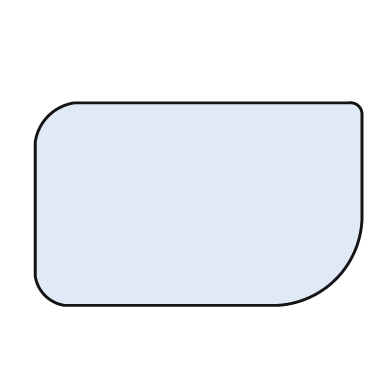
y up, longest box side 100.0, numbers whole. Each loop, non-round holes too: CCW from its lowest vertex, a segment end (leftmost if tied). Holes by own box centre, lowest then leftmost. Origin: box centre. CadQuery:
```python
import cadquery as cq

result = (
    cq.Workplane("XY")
    .moveTo(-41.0, -31.0)
    .lineTo(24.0, -31.0)
    .threePointArc((42.0, -23.0), (50.0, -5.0))
    .lineTo(50.0, 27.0)
    .threePointArc((49.0, 30.0), (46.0, 31.0))
    .lineTo(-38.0, 31.0)
    .threePointArc((-46.0, 27.0), (-50.0, 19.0))
    .lineTo(-50.0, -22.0)
    .threePointArc((-47.0, -28.0), (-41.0, -31.0))
    .close()
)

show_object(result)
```